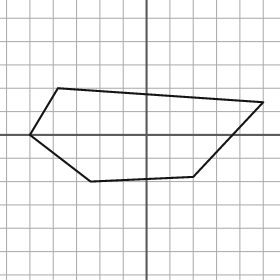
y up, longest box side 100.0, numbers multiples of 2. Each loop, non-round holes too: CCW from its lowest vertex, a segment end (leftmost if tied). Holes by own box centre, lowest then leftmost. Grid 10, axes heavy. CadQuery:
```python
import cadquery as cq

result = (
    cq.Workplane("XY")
    .moveTo(-24.0, -20.0)
    .lineTo(20.0, -18.0)
    .lineTo(50.0, 14.0)
    .lineTo(-38.0, 20.0)
    .lineTo(-50.0, 0.0)
    .close()
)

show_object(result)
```